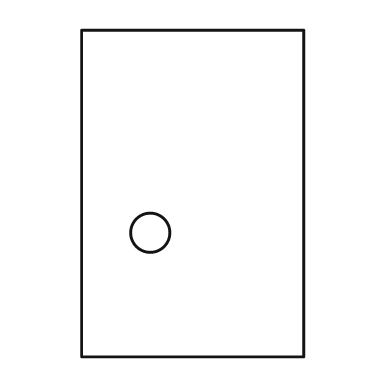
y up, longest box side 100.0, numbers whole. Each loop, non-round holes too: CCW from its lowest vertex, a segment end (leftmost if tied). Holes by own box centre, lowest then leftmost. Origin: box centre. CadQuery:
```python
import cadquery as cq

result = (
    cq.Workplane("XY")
    .moveTo(-34.0, -50.0)
    .lineTo(34.0, -50.0)
    .lineTo(34.0, 50.0)
    .lineTo(-34.0, 50.0)
    .close()
    .moveTo(-13.0, -12.0)
    .circle(6.0)
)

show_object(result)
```